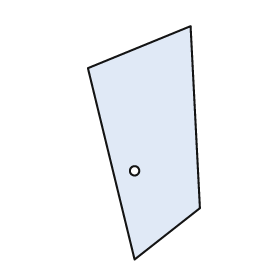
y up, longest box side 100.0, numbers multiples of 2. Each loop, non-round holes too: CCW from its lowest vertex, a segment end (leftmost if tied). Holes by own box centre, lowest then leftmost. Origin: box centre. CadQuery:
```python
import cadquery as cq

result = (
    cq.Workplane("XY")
    .moveTo(-4.0, -50.0)
    .lineTo(24.0, -28.0)
    .lineTo(20.0, 50.0)
    .lineTo(-24.0, 32.0)
    .close()
    .moveTo(-4.0, -12.0)
    .circle(2.0)
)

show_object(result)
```